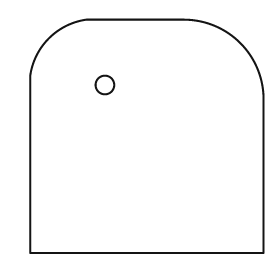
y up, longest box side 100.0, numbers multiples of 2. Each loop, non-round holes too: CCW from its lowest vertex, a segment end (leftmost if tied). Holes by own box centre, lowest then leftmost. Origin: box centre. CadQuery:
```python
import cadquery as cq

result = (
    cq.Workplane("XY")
    .moveTo(-50.0, -50.0)
    .lineTo(50.0, -50.0)
    .lineTo(50.0, 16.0)
    .threePointArc((40.0, 40.0), (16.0, 50.0))
    .lineTo(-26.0, 50.0)
    .threePointArc((-42.0, 42.0), (-50.0, 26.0))
    .close()
    .moveTo(-18.0, 22.0)
    .circle(4.0)
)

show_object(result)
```